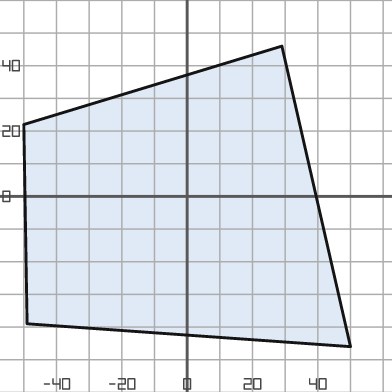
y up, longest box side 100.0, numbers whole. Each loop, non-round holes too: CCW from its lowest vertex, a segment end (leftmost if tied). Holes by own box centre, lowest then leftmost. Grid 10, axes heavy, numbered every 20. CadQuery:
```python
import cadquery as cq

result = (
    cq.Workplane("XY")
    .moveTo(50.0, -46.0)
    .lineTo(29.0, 46.0)
    .lineTo(-50.0, 22.0)
    .lineTo(-49.0, -39.0)
    .close()
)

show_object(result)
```